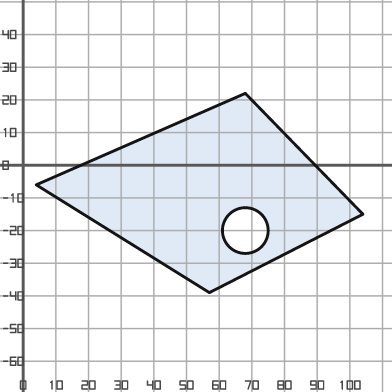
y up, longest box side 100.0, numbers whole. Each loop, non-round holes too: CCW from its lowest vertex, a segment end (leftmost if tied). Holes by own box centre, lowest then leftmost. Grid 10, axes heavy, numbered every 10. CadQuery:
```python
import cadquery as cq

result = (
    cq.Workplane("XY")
    .moveTo(57.0, -39.0)
    .lineTo(104.0, -15.0)
    .lineTo(68.0, 22.0)
    .lineTo(4.0, -6.0)
    .close()
    .moveTo(68.0, -20.0)
    .circle(7.0)
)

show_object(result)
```